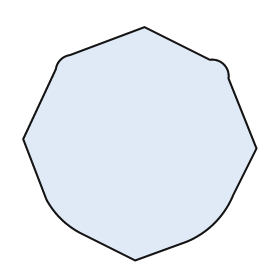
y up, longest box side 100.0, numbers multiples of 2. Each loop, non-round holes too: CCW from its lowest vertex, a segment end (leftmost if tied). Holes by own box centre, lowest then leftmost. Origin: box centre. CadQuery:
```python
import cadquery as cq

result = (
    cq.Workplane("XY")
    .moveTo(-2.0, -50.0)
    .lineTo(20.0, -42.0)
    .threePointArc((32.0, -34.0), (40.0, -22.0))
    .lineTo(50.0, -2.0)
    .lineTo(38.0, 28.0)
    .threePointArc((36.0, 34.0), (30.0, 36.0))
    .lineTo(2.0, 50.0)
    .lineTo(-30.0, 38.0)
    .threePointArc((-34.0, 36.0), (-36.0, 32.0))
    .lineTo(-50.0, 2.0)
    .lineTo(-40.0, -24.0)
    .threePointArc((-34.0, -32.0), (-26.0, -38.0))
    .close()
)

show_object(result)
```